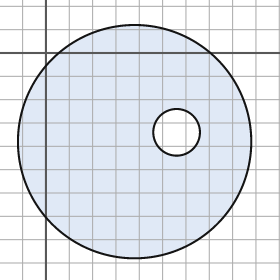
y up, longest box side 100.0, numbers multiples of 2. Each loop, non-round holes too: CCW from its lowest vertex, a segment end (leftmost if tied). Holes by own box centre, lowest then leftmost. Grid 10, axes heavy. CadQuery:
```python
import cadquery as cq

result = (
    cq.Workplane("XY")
    .moveTo(38.0, -38.0)
    .circle(50.0)
    .moveTo(56.0, -34.0)
    .circle(10.0)
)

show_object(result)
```